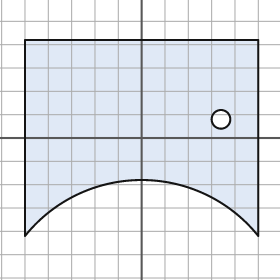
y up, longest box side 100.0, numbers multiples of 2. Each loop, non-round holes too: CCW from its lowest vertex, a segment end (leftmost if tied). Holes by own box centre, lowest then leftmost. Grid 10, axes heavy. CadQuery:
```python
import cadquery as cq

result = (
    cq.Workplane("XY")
    .moveTo(-50.0, -42.0)
    .threePointArc((0.0, -18.0), (50.0, -42.0))
    .lineTo(50.0, 42.0)
    .lineTo(-50.0, 42.0)
    .close()
    .moveTo(34.0, 8.0)
    .circle(4.0)
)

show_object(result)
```